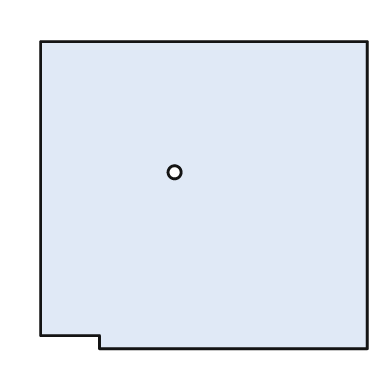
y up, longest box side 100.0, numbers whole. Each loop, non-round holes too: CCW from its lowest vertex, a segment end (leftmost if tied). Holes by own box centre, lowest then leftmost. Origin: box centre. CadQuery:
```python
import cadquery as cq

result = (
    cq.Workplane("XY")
    .moveTo(-32.0, -47.0)
    .lineTo(50.0, -47.0)
    .lineTo(50.0, 47.0)
    .lineTo(-50.0, 47.0)
    .lineTo(-50.0, -43.0)
    .lineTo(-32.0, -43.0)
    .close()
    .moveTo(-9.0, 7.0)
    .circle(2.0)
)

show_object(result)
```